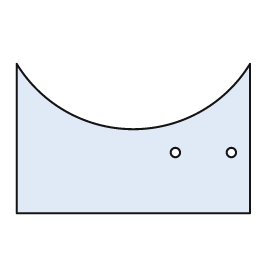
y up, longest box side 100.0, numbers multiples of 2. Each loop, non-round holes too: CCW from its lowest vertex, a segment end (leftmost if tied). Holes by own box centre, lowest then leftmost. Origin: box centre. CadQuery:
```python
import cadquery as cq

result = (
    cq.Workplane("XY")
    .moveTo(-50.0, -32.0)
    .lineTo(50.0, -32.0)
    .lineTo(50.0, 32.0)
    .threePointArc((0.0, 4.0), (-50.0, 32.0))
    .close()
    .moveTo(18.0, -6.0)
    .circle(2.0)
    .moveTo(42.0, -6.0)
    .circle(2.0)
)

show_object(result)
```